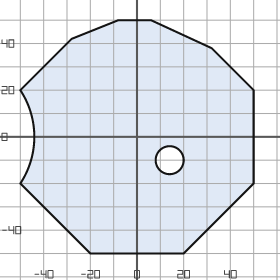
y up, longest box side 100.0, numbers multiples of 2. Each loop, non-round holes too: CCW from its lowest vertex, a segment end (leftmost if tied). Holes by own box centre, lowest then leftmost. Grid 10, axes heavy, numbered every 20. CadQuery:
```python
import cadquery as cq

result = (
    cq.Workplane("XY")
    .moveTo(-20.0, -50.0)
    .lineTo(20.0, -50.0)
    .lineTo(50.0, -20.0)
    .lineTo(50.0, 20.0)
    .lineTo(32.0, 38.0)
    .lineTo(6.0, 50.0)
    .lineTo(-8.0, 50.0)
    .lineTo(-28.0, 42.0)
    .lineTo(-50.0, 20.0)
    .threePointArc((-44.0, 0.0), (-50.0, -20.0))
    .close()
    .moveTo(14.0, -10.0)
    .circle(6.0)
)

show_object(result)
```